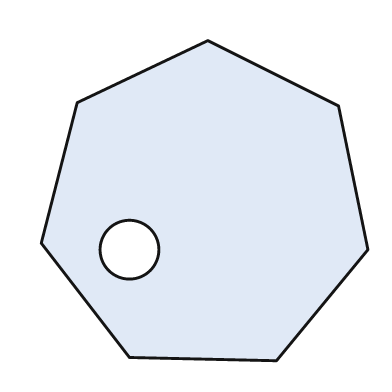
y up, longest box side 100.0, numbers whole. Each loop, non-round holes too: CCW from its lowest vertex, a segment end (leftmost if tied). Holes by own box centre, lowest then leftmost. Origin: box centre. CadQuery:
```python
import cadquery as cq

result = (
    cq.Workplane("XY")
    .moveTo(22.0, -49.0)
    .lineTo(50.0, -15.0)
    .lineTo(41.0, 29.0)
    .lineTo(1.0, 49.0)
    .lineTo(-39.0, 30.0)
    .lineTo(-50.0, -13.0)
    .lineTo(-23.0, -48.0)
    .close()
    .moveTo(-23.0, -15.0)
    .circle(9.0)
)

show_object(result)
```